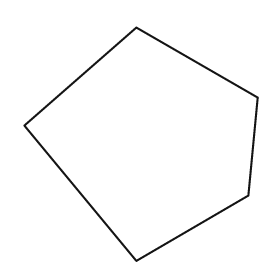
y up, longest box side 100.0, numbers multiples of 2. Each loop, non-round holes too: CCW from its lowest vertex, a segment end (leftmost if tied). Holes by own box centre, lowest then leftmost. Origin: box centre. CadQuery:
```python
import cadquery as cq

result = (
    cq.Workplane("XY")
    .moveTo(-2.0, -50.0)
    .lineTo(46.0, -22.0)
    .lineTo(50.0, 20.0)
    .lineTo(-2.0, 50.0)
    .lineTo(-50.0, 8.0)
    .close()
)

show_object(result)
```